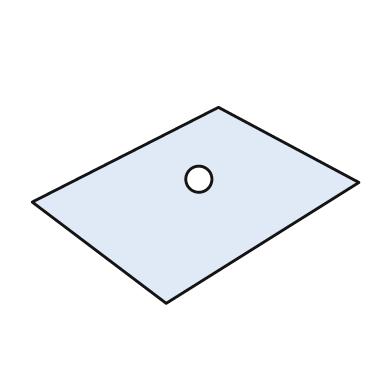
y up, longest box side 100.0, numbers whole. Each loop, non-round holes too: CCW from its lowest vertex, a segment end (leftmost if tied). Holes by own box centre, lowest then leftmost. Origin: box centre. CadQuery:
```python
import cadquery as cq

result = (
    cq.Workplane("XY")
    .moveTo(-9.0, -30.0)
    .lineTo(50.0, 7.0)
    .lineTo(7.0, 30.0)
    .lineTo(-50.0, 1.0)
    .close()
    .moveTo(1.0, 8.0)
    .circle(4.0)
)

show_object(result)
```